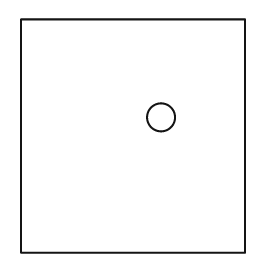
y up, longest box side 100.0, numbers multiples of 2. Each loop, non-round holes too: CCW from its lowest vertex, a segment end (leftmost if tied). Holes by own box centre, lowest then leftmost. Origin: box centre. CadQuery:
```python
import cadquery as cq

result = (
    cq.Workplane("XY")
    .moveTo(-48.0, -50.0)
    .lineTo(48.0, -50.0)
    .lineTo(48.0, 50.0)
    .lineTo(-48.0, 50.0)
    .close()
    .moveTo(12.0, 8.0)
    .circle(6.0)
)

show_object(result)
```